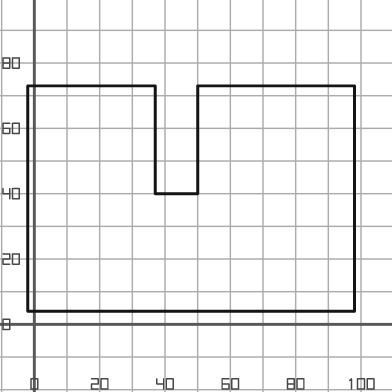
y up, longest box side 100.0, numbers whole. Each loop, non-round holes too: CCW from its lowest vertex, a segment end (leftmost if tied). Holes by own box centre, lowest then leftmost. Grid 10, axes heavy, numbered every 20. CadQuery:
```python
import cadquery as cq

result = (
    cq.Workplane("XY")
    .moveTo(-2.0, 4.0)
    .lineTo(98.0, 4.0)
    .lineTo(98.0, 73.0)
    .lineTo(50.0, 73.0)
    .lineTo(50.0, 40.0)
    .lineTo(37.0, 40.0)
    .lineTo(37.0, 73.0)
    .lineTo(-2.0, 73.0)
    .close()
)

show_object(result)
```